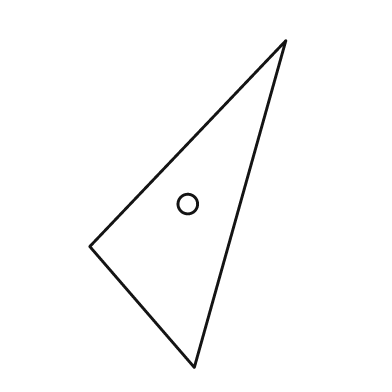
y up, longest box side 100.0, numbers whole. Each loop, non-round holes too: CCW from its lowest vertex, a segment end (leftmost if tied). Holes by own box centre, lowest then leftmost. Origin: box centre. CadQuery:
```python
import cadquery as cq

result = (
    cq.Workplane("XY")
    .moveTo(2.0, -50.0)
    .lineTo(30.0, 50.0)
    .lineTo(-30.0, -13.0)
    .close()
    .moveTo(0.0, 0.0)
    .circle(3.0)
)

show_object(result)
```